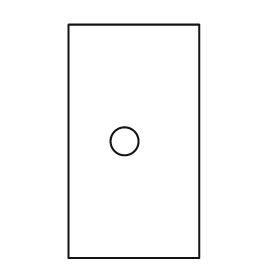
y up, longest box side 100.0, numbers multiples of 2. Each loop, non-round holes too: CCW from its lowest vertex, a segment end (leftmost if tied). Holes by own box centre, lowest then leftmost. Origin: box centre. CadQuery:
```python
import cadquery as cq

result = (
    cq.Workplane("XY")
    .moveTo(-28.0, -50.0)
    .lineTo(28.0, -50.0)
    .lineTo(28.0, 50.0)
    .lineTo(-28.0, 50.0)
    .close()
    .moveTo(-4.0, 0.0)
    .circle(6.0)
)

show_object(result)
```